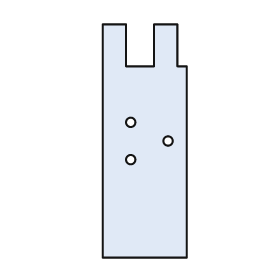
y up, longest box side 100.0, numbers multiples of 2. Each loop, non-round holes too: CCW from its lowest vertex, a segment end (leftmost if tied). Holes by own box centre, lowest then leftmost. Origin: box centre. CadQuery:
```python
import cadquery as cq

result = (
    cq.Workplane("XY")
    .moveTo(-18.0, -50.0)
    .lineTo(18.0, -50.0)
    .lineTo(18.0, 32.0)
    .lineTo(14.0, 32.0)
    .lineTo(14.0, 50.0)
    .lineTo(4.0, 50.0)
    .lineTo(4.0, 32.0)
    .lineTo(-8.0, 32.0)
    .lineTo(-8.0, 50.0)
    .lineTo(-18.0, 50.0)
    .close()
    .moveTo(-6.0, -8.0)
    .circle(2.0)
    .moveTo(10.0, 0.0)
    .circle(2.0)
    .moveTo(-6.0, 8.0)
    .circle(2.0)
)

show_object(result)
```